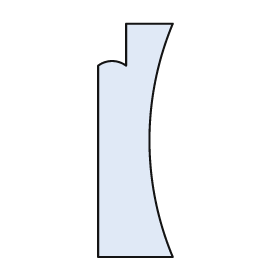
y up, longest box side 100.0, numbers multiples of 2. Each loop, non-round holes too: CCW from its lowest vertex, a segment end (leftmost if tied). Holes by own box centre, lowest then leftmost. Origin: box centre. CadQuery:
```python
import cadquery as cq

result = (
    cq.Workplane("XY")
    .moveTo(-16.0, -50.0)
    .lineTo(16.0, -50.0)
    .threePointArc((6.0, 0.0), (16.0, 50.0))
    .lineTo(-4.0, 50.0)
    .lineTo(-4.0, 32.0)
    .threePointArc((-10.0, 34.0), (-16.0, 32.0))
    .close()
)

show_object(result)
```